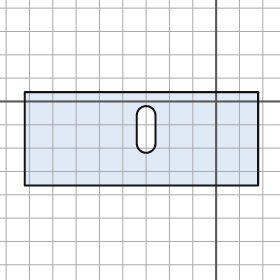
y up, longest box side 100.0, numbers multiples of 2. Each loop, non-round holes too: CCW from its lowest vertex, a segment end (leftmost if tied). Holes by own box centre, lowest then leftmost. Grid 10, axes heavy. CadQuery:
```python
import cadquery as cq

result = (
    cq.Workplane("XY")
    .moveTo(-82.0, -36.0)
    .lineTo(18.0, -36.0)
    .lineTo(18.0, 4.0)
    .lineTo(-82.0, 4.0)
    .close()
    .moveTo(-34.0, -18.0)
    .threePointArc((-30.0, -22.0), (-26.0, -18.0))
    .lineTo(-26.0, -6.0)
    .threePointArc((-30.0, -2.0), (-34.0, -6.0))
    .close()
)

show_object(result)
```